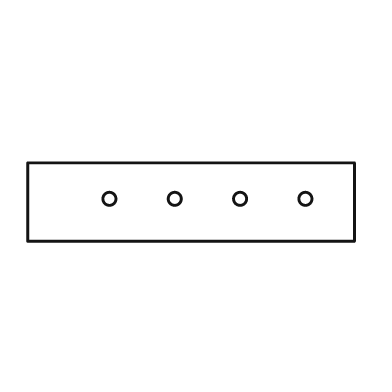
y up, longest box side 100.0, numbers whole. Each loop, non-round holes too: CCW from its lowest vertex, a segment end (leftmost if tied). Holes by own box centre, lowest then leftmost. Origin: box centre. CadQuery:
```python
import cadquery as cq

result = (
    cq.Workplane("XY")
    .moveTo(-50.0, -12.0)
    .lineTo(50.0, -12.0)
    .lineTo(50.0, 12.0)
    .lineTo(-50.0, 12.0)
    .close()
    .moveTo(-25.0, 1.0)
    .circle(2.0)
    .moveTo(-5.0, 1.0)
    .circle(2.0)
    .moveTo(15.0, 1.0)
    .circle(2.0)
    .moveTo(35.0, 1.0)
    .circle(2.0)
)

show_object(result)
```